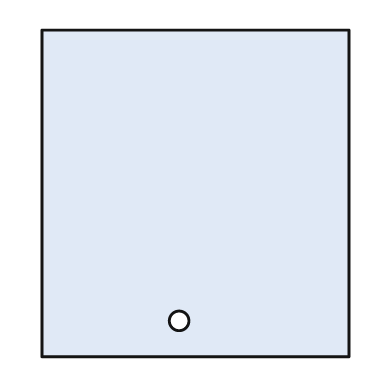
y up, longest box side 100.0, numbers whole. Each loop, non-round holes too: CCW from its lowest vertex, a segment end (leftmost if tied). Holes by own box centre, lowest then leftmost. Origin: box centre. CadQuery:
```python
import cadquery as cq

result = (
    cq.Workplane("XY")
    .moveTo(-47.0, -50.0)
    .lineTo(47.0, -50.0)
    .lineTo(47.0, 50.0)
    .lineTo(-47.0, 50.0)
    .close()
    .moveTo(-5.0, -39.0)
    .circle(3.0)
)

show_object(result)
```